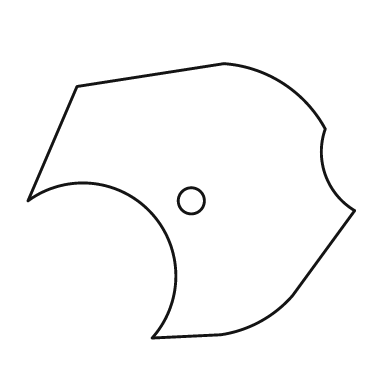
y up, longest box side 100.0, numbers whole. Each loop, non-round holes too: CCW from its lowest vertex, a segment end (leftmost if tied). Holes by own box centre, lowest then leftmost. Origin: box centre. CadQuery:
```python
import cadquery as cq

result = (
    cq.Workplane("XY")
    .moveTo(-12.0, -42.0)
    .lineTo(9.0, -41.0)
    .threePointArc((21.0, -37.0), (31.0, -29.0))
    .lineTo(50.0, -3.0)
    .threePointArc((41.0, 8.0), (41.0, 22.0))
    .threePointArc((28.0, 36.0), (10.0, 42.0))
    .lineTo(-35.0, 35.0)
    .lineTo(-50.0, 0.0)
    .threePointArc((-12.0, -4.0), (-12.0, -42.0))
    .close()
    .moveTo(0.0, 0.0)
    .circle(4.0)
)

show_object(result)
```